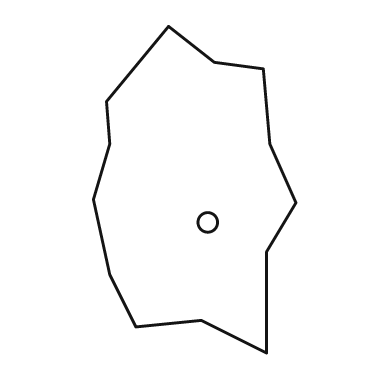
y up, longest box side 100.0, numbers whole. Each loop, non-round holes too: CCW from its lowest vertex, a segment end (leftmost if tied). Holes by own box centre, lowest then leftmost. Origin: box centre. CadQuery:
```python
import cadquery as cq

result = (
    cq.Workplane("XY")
    .moveTo(22.0, -50.0)
    .lineTo(22.0, -19.0)
    .lineTo(31.0, -4.0)
    .lineTo(23.0, 14.0)
    .lineTo(21.0, 37.0)
    .lineTo(6.0, 39.0)
    .lineTo(-8.0, 50.0)
    .lineTo(-27.0, 27.0)
    .lineTo(-26.0, 14.0)
    .lineTo(-31.0, -3.0)
    .lineTo(-26.0, -26.0)
    .lineTo(-18.0, -42.0)
    .lineTo(2.0, -40.0)
    .close()
    .moveTo(4.0, -10.0)
    .circle(3.0)
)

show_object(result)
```